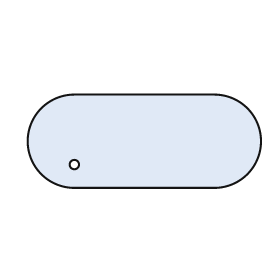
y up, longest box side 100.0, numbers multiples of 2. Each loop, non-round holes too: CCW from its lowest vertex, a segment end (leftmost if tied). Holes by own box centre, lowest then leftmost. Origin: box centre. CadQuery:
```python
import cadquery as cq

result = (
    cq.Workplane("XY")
    .moveTo(-30.0, -20.0)
    .lineTo(30.0, -20.0)
    .threePointArc((50.0, 0.0), (30.0, 20.0))
    .lineTo(-30.0, 20.0)
    .threePointArc((-50.0, 0.0), (-30.0, -20.0))
    .close()
    .moveTo(-30.0, -10.0)
    .circle(2.0)
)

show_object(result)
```